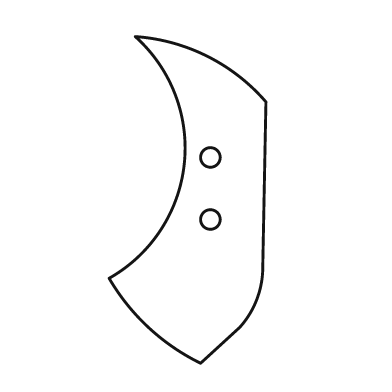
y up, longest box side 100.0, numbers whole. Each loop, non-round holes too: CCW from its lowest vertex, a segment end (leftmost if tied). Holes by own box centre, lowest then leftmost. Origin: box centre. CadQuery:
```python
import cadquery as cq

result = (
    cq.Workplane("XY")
    .moveTo(4.0, -50.0)
    .lineTo(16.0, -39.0)
    .threePointArc((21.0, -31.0), (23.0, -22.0))
    .lineTo(24.0, 30.0)
    .threePointArc((6.0, 44.0), (-16.0, 50.0))
    .threePointArc((-1.0, 11.0), (-24.0, -24.0))
    .threePointArc((-12.0, -39.0), (4.0, -50.0))
    .close()
    .moveTo(7.0, -6.0)
    .circle(3.0)
    .moveTo(7.0, 13.0)
    .circle(3.0)
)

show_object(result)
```